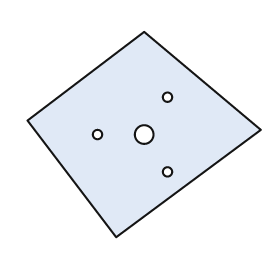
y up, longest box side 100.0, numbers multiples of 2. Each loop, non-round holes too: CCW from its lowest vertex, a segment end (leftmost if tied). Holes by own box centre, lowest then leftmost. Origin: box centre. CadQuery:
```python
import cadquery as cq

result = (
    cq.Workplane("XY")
    .moveTo(-12.0, -44.0)
    .lineTo(50.0, 2.0)
    .lineTo(0.0, 44.0)
    .lineTo(-50.0, 6.0)
    .close()
    .moveTo(10.0, -16.0)
    .circle(2.0)
    .moveTo(-20.0, 0.0)
    .circle(2.0)
    .moveTo(0.0, 0.0)
    .circle(4.0)
    .moveTo(10.0, 16.0)
    .circle(2.0)
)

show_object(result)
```